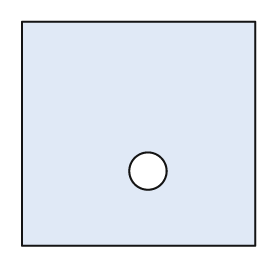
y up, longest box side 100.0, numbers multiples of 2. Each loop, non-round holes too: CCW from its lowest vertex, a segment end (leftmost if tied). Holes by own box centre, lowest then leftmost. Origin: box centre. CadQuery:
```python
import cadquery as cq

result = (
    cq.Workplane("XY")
    .moveTo(-50.0, -48.0)
    .lineTo(50.0, -48.0)
    .lineTo(50.0, 48.0)
    .lineTo(-50.0, 48.0)
    .close()
    .moveTo(4.0, -16.0)
    .circle(8.0)
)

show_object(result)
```